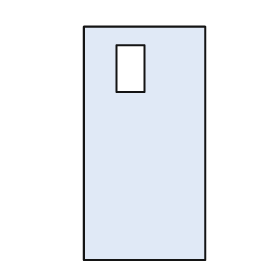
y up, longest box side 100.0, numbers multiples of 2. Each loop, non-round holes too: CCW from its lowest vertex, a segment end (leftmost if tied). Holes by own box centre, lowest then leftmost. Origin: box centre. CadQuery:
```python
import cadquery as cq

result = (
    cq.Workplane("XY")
    .moveTo(-26.0, -50.0)
    .lineTo(26.0, -50.0)
    .lineTo(26.0, 50.0)
    .lineTo(-26.0, 50.0)
    .close()
    .moveTo(-12.0, 22.0)
    .lineTo(0.0, 22.0)
    .lineTo(0.0, 42.0)
    .lineTo(-12.0, 42.0)
    .close()
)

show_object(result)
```